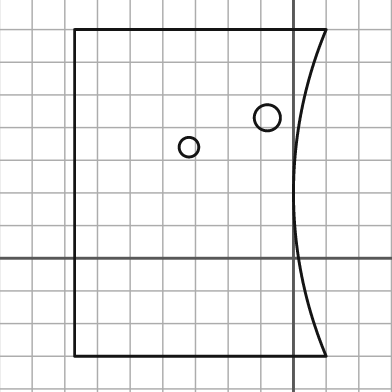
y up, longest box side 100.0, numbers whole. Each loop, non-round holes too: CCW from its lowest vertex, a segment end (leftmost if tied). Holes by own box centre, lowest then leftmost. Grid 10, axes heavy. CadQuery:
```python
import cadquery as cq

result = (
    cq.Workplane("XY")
    .moveTo(-67.0, -30.0)
    .lineTo(10.0, -30.0)
    .threePointArc((0.0, 20.0), (10.0, 70.0))
    .lineTo(-67.0, 70.0)
    .close()
    .moveTo(-32.0, 34.0)
    .circle(3.0)
    .moveTo(-8.0, 43.0)
    .circle(4.0)
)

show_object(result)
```